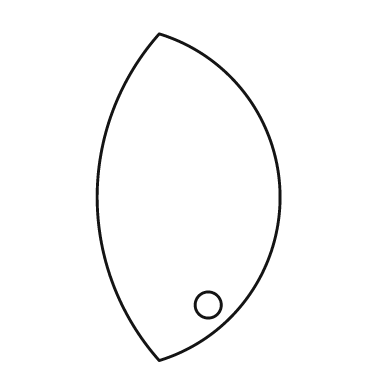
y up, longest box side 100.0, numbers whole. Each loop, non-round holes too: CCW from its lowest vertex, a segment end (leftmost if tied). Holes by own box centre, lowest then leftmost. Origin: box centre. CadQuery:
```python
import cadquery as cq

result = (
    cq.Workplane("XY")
    .moveTo(-9.0, -50.0)
    .threePointArc((28.0, 0.0), (-9.0, 50.0))
    .threePointArc((-28.0, 0.0), (-9.0, -50.0))
    .close()
    .moveTo(6.0, -33.0)
    .circle(4.0)
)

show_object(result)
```